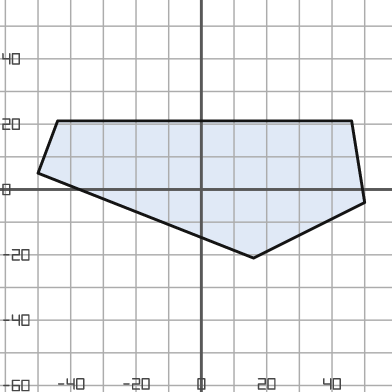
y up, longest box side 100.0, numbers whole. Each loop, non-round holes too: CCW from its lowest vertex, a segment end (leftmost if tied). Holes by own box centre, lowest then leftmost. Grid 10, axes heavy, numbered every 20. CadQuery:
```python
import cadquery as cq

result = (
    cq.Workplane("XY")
    .moveTo(16.0, -21.0)
    .lineTo(50.0, -4.0)
    .lineTo(46.0, 21.0)
    .lineTo(-44.0, 21.0)
    .lineTo(-50.0, 5.0)
    .close()
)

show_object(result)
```